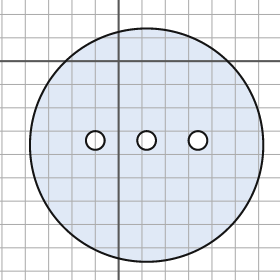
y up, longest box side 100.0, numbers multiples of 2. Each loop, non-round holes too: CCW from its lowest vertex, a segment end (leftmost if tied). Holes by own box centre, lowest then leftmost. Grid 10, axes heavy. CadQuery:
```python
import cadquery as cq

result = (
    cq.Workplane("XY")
    .moveTo(12.0, -36.0)
    .circle(50.0)
    .moveTo(-10.0, -34.0)
    .circle(4.0)
    .moveTo(12.0, -34.0)
    .circle(4.0)
    .moveTo(34.0, -34.0)
    .circle(4.0)
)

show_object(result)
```